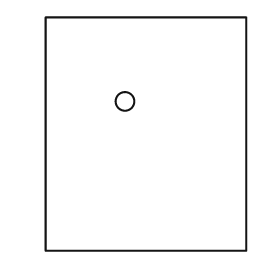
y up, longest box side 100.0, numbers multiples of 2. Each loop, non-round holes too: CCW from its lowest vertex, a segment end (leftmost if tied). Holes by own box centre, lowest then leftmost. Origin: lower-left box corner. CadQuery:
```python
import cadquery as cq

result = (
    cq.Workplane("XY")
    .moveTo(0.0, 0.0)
    .lineTo(86.0, 0.0)
    .lineTo(86.0, 100.0)
    .lineTo(0.0, 100.0)
    .close()
    .moveTo(34.0, 64.0)
    .circle(4.0)
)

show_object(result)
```